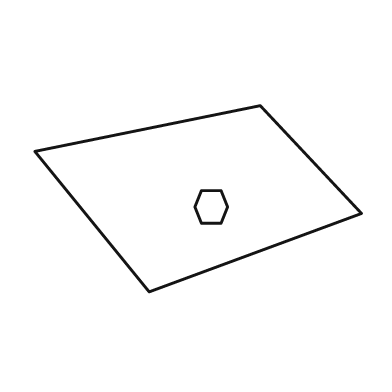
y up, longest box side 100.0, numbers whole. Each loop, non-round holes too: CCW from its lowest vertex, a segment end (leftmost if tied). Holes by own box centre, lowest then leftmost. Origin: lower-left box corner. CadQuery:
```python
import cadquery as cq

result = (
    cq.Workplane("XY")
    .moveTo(35.0, 0.0)
    .lineTo(100.0, 24.0)
    .lineTo(69.0, 57.0)
    .lineTo(0.0, 43.0)
    .close()
    .moveTo(51.0, 21.0)
    .lineTo(57.0, 21.0)
    .lineTo(59.0, 26.0)
    .lineTo(57.0, 31.0)
    .lineTo(51.0, 31.0)
    .lineTo(49.0, 26.0)
    .close()
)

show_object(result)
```